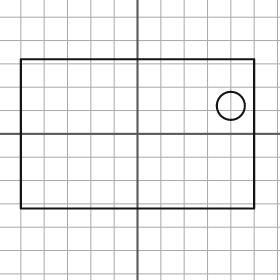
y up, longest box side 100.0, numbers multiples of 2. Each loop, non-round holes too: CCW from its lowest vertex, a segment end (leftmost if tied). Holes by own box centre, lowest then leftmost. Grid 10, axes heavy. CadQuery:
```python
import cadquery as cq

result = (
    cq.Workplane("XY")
    .moveTo(-50.0, -32.0)
    .lineTo(50.0, -32.0)
    .lineTo(50.0, 32.0)
    .lineTo(-50.0, 32.0)
    .close()
    .moveTo(40.0, 12.0)
    .circle(6.0)
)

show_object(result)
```